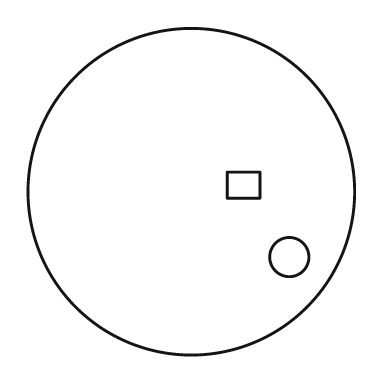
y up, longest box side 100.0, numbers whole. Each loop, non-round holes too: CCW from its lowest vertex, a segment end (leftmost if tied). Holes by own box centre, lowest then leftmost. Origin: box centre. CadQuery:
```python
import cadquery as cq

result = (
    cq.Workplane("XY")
    .moveTo(0.0, 0.0)
    .circle(50.0)
    .moveTo(30.0, -20.0)
    .circle(6.0)
    .moveTo(11.0, -2.0)
    .lineTo(21.0, -2.0)
    .lineTo(21.0, 6.0)
    .lineTo(11.0, 6.0)
    .close()
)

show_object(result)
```